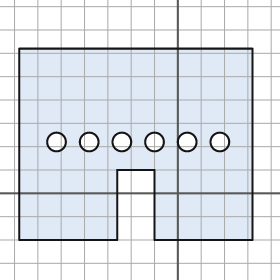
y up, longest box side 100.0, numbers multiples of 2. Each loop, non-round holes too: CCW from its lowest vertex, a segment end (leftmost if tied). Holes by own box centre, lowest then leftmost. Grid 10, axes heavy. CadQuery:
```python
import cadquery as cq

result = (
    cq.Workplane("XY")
    .moveTo(-68.0, -20.0)
    .lineTo(-26.0, -20.0)
    .lineTo(-26.0, 10.0)
    .lineTo(-10.0, 10.0)
    .lineTo(-10.0, -20.0)
    .lineTo(32.0, -20.0)
    .lineTo(32.0, 62.0)
    .lineTo(-68.0, 62.0)
    .close()
    .moveTo(-52.0, 22.0)
    .circle(4.0)
    .moveTo(-38.0, 22.0)
    .circle(4.0)
    .moveTo(-24.0, 22.0)
    .circle(4.0)
    .moveTo(-10.0, 22.0)
    .circle(4.0)
    .moveTo(4.0, 22.0)
    .circle(4.0)
    .moveTo(18.0, 22.0)
    .circle(4.0)
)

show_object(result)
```